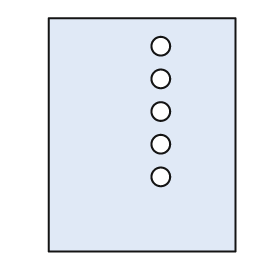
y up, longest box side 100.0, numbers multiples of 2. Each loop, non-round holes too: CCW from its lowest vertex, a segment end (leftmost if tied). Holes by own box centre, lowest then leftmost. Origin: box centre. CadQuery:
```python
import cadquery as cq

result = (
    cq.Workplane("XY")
    .moveTo(-40.0, -50.0)
    .lineTo(40.0, -50.0)
    .lineTo(40.0, 50.0)
    .lineTo(-40.0, 50.0)
    .close()
    .moveTo(8.0, -18.0)
    .circle(4.0)
    .moveTo(8.0, -4.0)
    .circle(4.0)
    .moveTo(8.0, 10.0)
    .circle(4.0)
    .moveTo(8.0, 24.0)
    .circle(4.0)
    .moveTo(8.0, 38.0)
    .circle(4.0)
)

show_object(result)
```